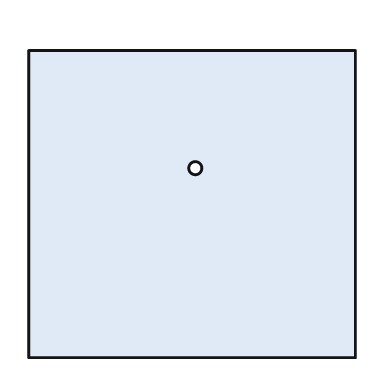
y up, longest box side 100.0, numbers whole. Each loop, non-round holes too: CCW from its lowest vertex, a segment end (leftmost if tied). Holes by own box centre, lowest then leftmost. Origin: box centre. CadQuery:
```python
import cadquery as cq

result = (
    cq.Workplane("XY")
    .moveTo(-50.0, -47.0)
    .lineTo(50.0, -47.0)
    .lineTo(50.0, 47.0)
    .lineTo(-50.0, 47.0)
    .close()
    .moveTo(1.0, 11.0)
    .circle(2.0)
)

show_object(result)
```